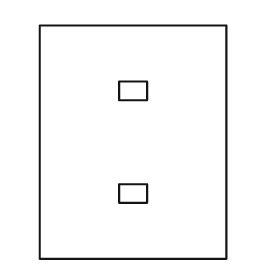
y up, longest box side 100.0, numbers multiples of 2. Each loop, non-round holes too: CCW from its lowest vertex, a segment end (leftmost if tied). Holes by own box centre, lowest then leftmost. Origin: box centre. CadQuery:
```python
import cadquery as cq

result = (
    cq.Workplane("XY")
    .moveTo(-40.0, -50.0)
    .lineTo(40.0, -50.0)
    .lineTo(40.0, 50.0)
    .lineTo(-40.0, 50.0)
    .close()
    .moveTo(-6.0, -26.0)
    .lineTo(6.0, -26.0)
    .lineTo(6.0, -18.0)
    .lineTo(-6.0, -18.0)
    .close()
    .moveTo(-6.0, 18.0)
    .lineTo(6.0, 18.0)
    .lineTo(6.0, 26.0)
    .lineTo(-6.0, 26.0)
    .close()
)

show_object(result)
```